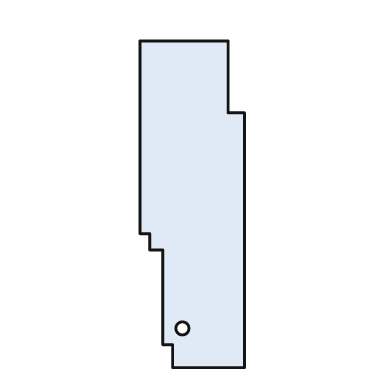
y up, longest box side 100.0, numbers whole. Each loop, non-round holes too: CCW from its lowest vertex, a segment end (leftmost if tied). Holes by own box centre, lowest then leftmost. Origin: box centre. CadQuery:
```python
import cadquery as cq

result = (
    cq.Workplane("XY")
    .moveTo(-6.0, -50.0)
    .lineTo(16.0, -50.0)
    .lineTo(16.0, 28.0)
    .lineTo(11.0, 28.0)
    .lineTo(11.0, 50.0)
    .lineTo(-16.0, 50.0)
    .lineTo(-16.0, -9.0)
    .lineTo(-13.0, -9.0)
    .lineTo(-13.0, -14.0)
    .lineTo(-9.0, -14.0)
    .lineTo(-9.0, -43.0)
    .lineTo(-6.0, -43.0)
    .close()
    .moveTo(-3.0, -38.0)
    .circle(2.0)
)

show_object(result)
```